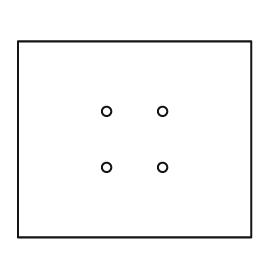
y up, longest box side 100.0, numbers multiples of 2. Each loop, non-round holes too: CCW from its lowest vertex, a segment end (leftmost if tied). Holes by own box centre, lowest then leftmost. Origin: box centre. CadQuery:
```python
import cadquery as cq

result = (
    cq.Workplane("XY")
    .moveTo(-50.0, -42.0)
    .lineTo(50.0, -42.0)
    .lineTo(50.0, 42.0)
    .lineTo(-50.0, 42.0)
    .close()
    .moveTo(-12.0, -12.0)
    .circle(2.0)
    .moveTo(12.0, -12.0)
    .circle(2.0)
    .moveTo(-12.0, 12.0)
    .circle(2.0)
    .moveTo(12.0, 12.0)
    .circle(2.0)
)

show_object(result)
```